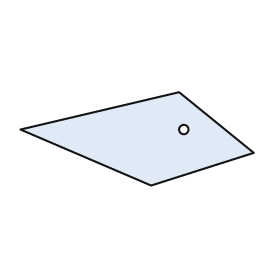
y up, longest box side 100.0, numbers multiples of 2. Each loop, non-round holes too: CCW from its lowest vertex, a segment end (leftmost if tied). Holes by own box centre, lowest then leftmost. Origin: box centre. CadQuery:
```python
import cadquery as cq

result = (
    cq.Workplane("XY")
    .moveTo(6.0, -20.0)
    .lineTo(50.0, -6.0)
    .lineTo(18.0, 20.0)
    .lineTo(-50.0, 4.0)
    .close()
    .moveTo(20.0, 4.0)
    .circle(2.0)
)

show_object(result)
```